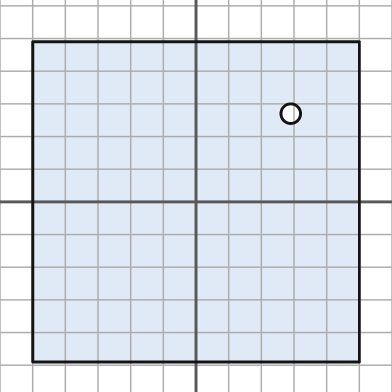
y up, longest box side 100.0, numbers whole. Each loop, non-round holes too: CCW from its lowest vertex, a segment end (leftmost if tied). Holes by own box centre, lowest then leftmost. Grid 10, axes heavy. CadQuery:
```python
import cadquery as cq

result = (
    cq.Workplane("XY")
    .moveTo(-50.0, -49.0)
    .lineTo(50.0, -49.0)
    .lineTo(50.0, 49.0)
    .lineTo(-50.0, 49.0)
    .close()
    .moveTo(29.0, 27.0)
    .circle(3.0)
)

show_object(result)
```